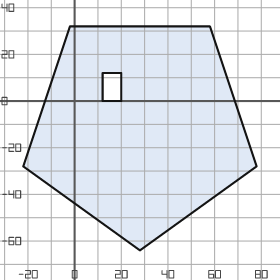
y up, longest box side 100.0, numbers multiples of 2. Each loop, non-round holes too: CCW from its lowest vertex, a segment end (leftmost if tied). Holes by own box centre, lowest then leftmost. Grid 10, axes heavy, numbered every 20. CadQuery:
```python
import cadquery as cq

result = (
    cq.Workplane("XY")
    .moveTo(28.0, -64.0)
    .lineTo(78.0, -28.0)
    .lineTo(58.0, 32.0)
    .lineTo(-2.0, 32.0)
    .lineTo(-22.0, -28.0)
    .close()
    .moveTo(12.0, 0.0)
    .lineTo(20.0, 0.0)
    .lineTo(20.0, 12.0)
    .lineTo(12.0, 12.0)
    .close()
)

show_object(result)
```